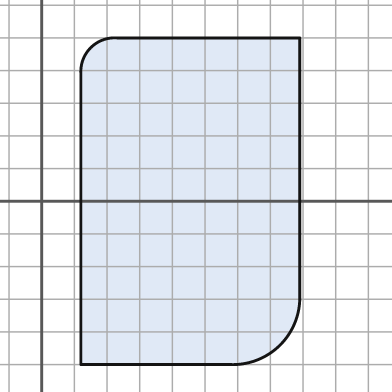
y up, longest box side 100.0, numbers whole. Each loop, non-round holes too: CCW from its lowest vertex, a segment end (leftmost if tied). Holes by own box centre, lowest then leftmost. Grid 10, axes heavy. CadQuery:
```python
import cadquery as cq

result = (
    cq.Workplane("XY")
    .moveTo(12.0, -50.0)
    .lineTo(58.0, -50.0)
    .threePointArc((73.0, -44.0), (79.0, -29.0))
    .lineTo(79.0, 50.0)
    .lineTo(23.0, 50.0)
    .threePointArc((15.0, 47.0), (12.0, 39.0))
    .close()
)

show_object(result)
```